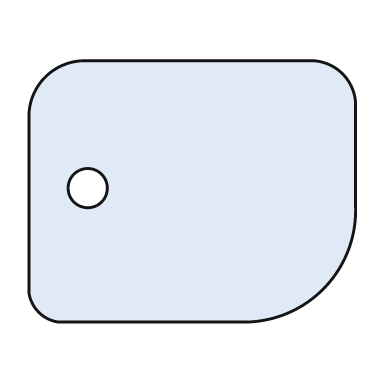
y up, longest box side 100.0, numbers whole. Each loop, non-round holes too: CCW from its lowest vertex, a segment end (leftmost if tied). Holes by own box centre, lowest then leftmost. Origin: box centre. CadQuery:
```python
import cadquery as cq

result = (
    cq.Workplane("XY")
    .moveTo(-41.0, -40.0)
    .lineTo(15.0, -40.0)
    .threePointArc((40.0, -30.0), (50.0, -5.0))
    .lineTo(50.0, 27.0)
    .threePointArc((46.0, 36.0), (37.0, 40.0))
    .lineTo(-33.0, 40.0)
    .threePointArc((-45.0, 35.0), (-50.0, 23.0))
    .lineTo(-50.0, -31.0)
    .threePointArc((-47.0, -37.0), (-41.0, -40.0))
    .close()
    .moveTo(-32.0, 1.0)
    .circle(6.0)
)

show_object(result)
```